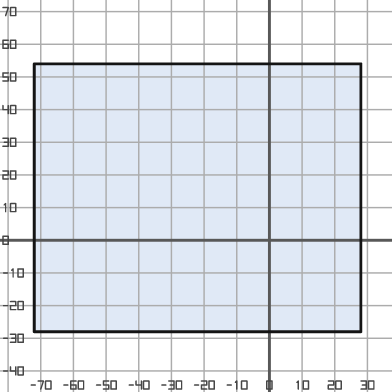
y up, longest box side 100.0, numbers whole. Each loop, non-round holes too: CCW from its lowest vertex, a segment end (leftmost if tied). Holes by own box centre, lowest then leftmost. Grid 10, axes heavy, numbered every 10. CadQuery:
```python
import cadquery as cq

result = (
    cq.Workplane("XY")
    .moveTo(-72.0, -28.0)
    .lineTo(28.0, -28.0)
    .lineTo(28.0, 54.0)
    .lineTo(-72.0, 54.0)
    .close()
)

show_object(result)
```